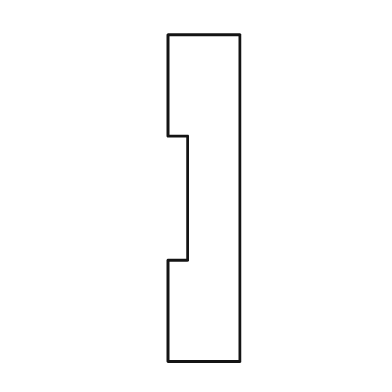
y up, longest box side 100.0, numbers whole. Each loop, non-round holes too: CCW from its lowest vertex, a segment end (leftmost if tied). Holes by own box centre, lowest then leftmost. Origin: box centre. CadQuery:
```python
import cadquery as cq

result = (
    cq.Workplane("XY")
    .moveTo(-11.0, -50.0)
    .lineTo(11.0, -50.0)
    .lineTo(11.0, 50.0)
    .lineTo(-11.0, 50.0)
    .lineTo(-11.0, 19.0)
    .lineTo(-5.0, 19.0)
    .lineTo(-5.0, -19.0)
    .lineTo(-11.0, -19.0)
    .close()
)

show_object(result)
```